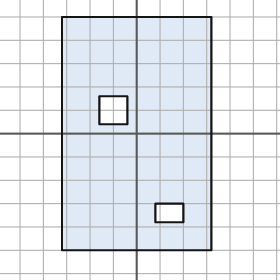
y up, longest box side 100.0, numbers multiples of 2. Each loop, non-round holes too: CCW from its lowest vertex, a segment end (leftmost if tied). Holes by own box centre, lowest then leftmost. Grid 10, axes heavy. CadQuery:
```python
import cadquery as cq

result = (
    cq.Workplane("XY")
    .moveTo(-32.0, -50.0)
    .lineTo(32.0, -50.0)
    .lineTo(32.0, 50.0)
    .lineTo(-32.0, 50.0)
    .close()
    .moveTo(8.0, -38.0)
    .lineTo(20.0, -38.0)
    .lineTo(20.0, -30.0)
    .lineTo(8.0, -30.0)
    .close()
    .moveTo(-16.0, 4.0)
    .lineTo(-4.0, 4.0)
    .lineTo(-4.0, 16.0)
    .lineTo(-16.0, 16.0)
    .close()
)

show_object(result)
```